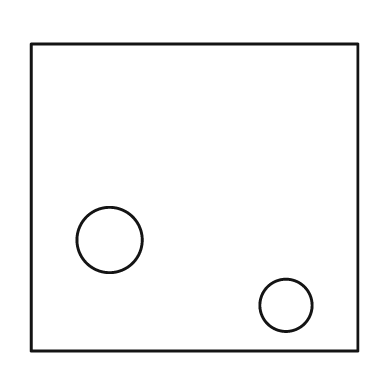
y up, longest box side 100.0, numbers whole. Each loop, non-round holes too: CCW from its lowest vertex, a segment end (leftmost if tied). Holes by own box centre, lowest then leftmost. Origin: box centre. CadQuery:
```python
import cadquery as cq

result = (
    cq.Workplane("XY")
    .moveTo(-50.0, -47.0)
    .lineTo(50.0, -47.0)
    .lineTo(50.0, 47.0)
    .lineTo(-50.0, 47.0)
    .close()
    .moveTo(28.0, -33.0)
    .circle(8.0)
    .moveTo(-26.0, -13.0)
    .circle(10.0)
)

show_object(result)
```